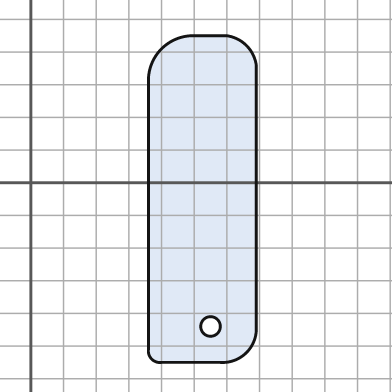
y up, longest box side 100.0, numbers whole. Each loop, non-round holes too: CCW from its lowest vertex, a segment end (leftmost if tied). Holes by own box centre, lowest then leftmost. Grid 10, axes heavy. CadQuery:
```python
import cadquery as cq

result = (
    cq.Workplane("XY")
    .moveTo(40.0, -55.0)
    .lineTo(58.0, -55.0)
    .threePointArc((66.0, -52.0), (69.0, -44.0))
    .lineTo(69.0, 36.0)
    .threePointArc((66.0, 42.0), (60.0, 45.0))
    .lineTo(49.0, 45.0)
    .threePointArc((40.0, 41.0), (36.0, 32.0))
    .lineTo(36.0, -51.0)
    .threePointArc((37.0, -54.0), (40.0, -55.0))
    .close()
    .moveTo(55.0, -44.0)
    .circle(3.0)
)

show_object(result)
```